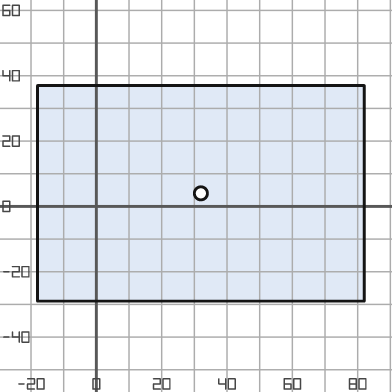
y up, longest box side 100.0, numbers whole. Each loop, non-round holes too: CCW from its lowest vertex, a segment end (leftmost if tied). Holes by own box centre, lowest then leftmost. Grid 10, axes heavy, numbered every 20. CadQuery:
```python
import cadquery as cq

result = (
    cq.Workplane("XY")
    .moveTo(-18.0, -29.0)
    .lineTo(82.0, -29.0)
    .lineTo(82.0, 37.0)
    .lineTo(-18.0, 37.0)
    .close()
    .moveTo(32.0, 4.0)
    .circle(2.0)
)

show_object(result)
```